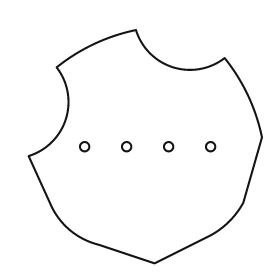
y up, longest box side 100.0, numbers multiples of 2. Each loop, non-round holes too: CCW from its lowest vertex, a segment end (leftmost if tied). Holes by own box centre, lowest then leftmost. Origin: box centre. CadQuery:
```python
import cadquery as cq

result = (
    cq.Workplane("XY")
    .moveTo(4.0, -50.0)
    .lineTo(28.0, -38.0)
    .threePointArc((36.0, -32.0), (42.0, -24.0))
    .lineTo(50.0, 4.0)
    .threePointArc((44.0, 22.0), (34.0, 38.0))
    .threePointArc((12.0, 34.0), (-4.0, 50.0))
    .threePointArc((-22.0, 44.0), (-38.0, 34.0))
    .threePointArc((-34.0, 12.0), (-50.0, -4.0))
    .lineTo(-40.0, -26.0)
    .threePointArc((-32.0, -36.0), (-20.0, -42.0))
    .close()
    .moveTo(-26.0, 0.0)
    .circle(2.0)
    .moveTo(-8.0, 0.0)
    .circle(2.0)
    .moveTo(10.0, 0.0)
    .circle(2.0)
    .moveTo(28.0, 0.0)
    .circle(2.0)
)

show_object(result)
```